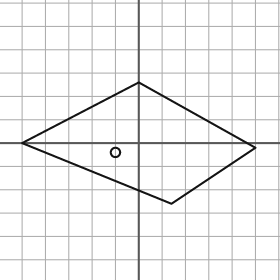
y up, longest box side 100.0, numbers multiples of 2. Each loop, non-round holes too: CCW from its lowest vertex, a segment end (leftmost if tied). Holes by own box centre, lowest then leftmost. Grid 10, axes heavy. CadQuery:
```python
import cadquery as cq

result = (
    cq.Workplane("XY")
    .moveTo(14.0, -26.0)
    .lineTo(50.0, -2.0)
    .lineTo(0.0, 26.0)
    .lineTo(-50.0, 0.0)
    .close()
    .moveTo(-10.0, -4.0)
    .circle(2.0)
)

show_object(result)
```